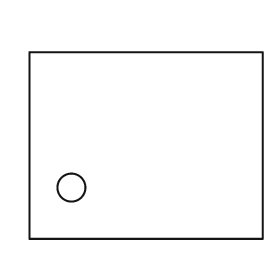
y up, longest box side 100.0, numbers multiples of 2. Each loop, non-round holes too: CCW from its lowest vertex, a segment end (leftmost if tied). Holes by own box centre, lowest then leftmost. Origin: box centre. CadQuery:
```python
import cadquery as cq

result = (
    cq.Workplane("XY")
    .moveTo(-50.0, -40.0)
    .lineTo(50.0, -40.0)
    .lineTo(50.0, 40.0)
    .lineTo(-50.0, 40.0)
    .close()
    .moveTo(-32.0, -18.0)
    .circle(6.0)
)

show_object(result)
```